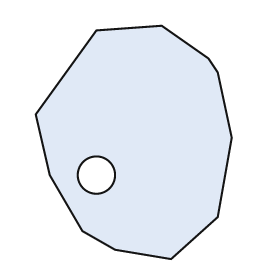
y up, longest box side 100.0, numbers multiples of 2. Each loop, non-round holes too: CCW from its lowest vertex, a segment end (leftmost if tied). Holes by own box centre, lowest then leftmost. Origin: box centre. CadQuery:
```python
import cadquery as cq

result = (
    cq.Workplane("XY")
    .moveTo(16.0, -50.0)
    .lineTo(36.0, -32.0)
    .lineTo(42.0, 2.0)
    .lineTo(36.0, 30.0)
    .lineTo(32.0, 36.0)
    .lineTo(12.0, 50.0)
    .lineTo(-16.0, 48.0)
    .lineTo(-42.0, 12.0)
    .lineTo(-36.0, -14.0)
    .lineTo(-22.0, -38.0)
    .lineTo(-8.0, -46.0)
    .close()
    .moveTo(-16.0, -14.0)
    .circle(8.0)
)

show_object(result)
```